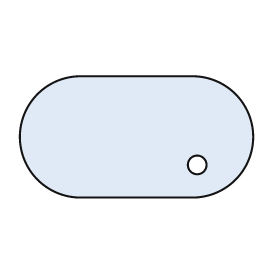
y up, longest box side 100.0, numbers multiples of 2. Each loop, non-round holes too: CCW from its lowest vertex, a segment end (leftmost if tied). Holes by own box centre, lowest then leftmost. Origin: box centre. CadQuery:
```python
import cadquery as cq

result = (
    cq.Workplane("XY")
    .moveTo(-24.0, -26.0)
    .lineTo(24.0, -26.0)
    .threePointArc((50.0, 0.0), (24.0, 26.0))
    .lineTo(-24.0, 26.0)
    .threePointArc((-50.0, 0.0), (-24.0, -26.0))
    .close()
    .moveTo(26.0, -12.0)
    .circle(4.0)
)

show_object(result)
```